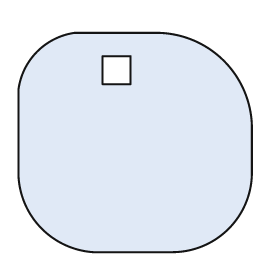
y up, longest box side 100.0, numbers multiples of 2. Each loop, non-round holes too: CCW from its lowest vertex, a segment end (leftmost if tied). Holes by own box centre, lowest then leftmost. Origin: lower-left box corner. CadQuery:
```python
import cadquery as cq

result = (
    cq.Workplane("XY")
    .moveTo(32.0, 0.0)
    .lineTo(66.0, 0.0)
    .threePointArc((90.0, 10.0), (100.0, 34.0))
    .lineTo(100.0, 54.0)
    .threePointArc((88.0, 82.0), (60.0, 94.0))
    .lineTo(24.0, 94.0)
    .threePointArc((8.0, 86.0), (0.0, 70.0))
    .lineTo(0.0, 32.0)
    .threePointArc((10.0, 10.0), (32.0, 0.0))
    .close()
    .moveTo(36.0, 72.0)
    .lineTo(48.0, 72.0)
    .lineTo(48.0, 84.0)
    .lineTo(36.0, 84.0)
    .close()
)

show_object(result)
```